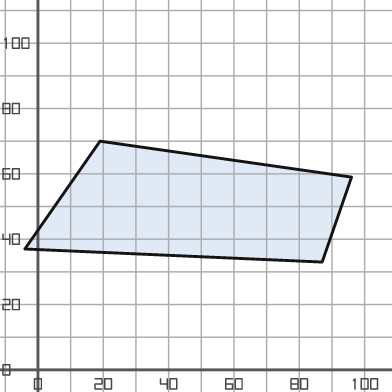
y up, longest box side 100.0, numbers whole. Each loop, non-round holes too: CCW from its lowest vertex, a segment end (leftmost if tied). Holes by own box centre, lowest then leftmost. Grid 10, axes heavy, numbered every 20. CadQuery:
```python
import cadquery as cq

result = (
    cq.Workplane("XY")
    .moveTo(87.0, 33.0)
    .lineTo(96.0, 59.0)
    .lineTo(19.0, 70.0)
    .lineTo(-4.0, 37.0)
    .close()
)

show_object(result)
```